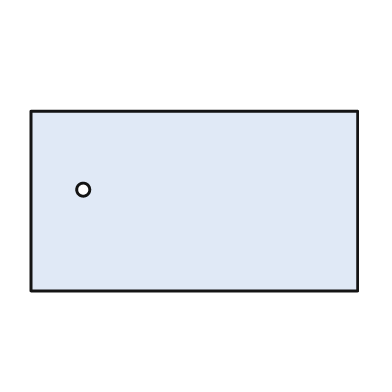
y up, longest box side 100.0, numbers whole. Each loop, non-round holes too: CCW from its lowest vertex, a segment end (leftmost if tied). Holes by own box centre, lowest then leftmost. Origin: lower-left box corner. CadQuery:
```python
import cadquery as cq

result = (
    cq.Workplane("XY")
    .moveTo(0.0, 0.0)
    .lineTo(100.0, 0.0)
    .lineTo(100.0, 55.0)
    .lineTo(0.0, 55.0)
    .close()
    .moveTo(16.0, 31.0)
    .circle(2.0)
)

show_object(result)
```